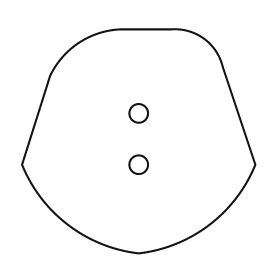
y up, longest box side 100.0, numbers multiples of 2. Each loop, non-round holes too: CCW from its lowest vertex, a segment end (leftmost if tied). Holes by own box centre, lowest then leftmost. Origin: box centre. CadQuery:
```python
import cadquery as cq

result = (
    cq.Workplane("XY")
    .moveTo(0.0, -48.0)
    .threePointArc((30.0, -36.0), (50.0, -10.0))
    .lineTo(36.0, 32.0)
    .threePointArc((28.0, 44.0), (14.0, 48.0))
    .lineTo(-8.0, 48.0)
    .threePointArc((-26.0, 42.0), (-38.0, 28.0))
    .lineTo(-50.0, -10.0)
    .threePointArc((-30.0, -36.0), (0.0, -48.0))
    .close()
    .moveTo(0.0, -10.0)
    .circle(4.0)
    .moveTo(0.0, 12.0)
    .circle(4.0)
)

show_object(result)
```